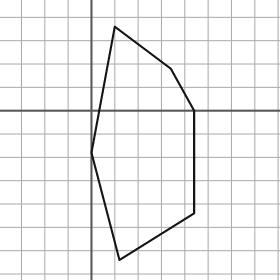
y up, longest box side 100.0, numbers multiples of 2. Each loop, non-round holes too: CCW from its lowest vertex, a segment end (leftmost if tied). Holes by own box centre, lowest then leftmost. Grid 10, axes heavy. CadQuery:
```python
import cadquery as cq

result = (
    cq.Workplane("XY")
    .moveTo(12.0, -64.0)
    .lineTo(44.0, -44.0)
    .lineTo(44.0, 0.0)
    .lineTo(34.0, 18.0)
    .lineTo(10.0, 36.0)
    .lineTo(0.0, -18.0)
    .close()
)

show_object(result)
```